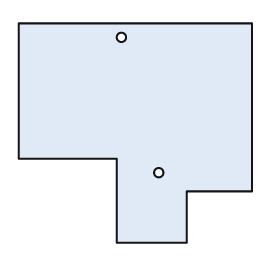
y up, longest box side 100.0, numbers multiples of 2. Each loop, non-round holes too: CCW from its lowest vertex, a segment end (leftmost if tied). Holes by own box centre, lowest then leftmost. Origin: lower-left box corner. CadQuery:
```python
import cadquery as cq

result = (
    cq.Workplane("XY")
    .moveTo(42.0, 0.0)
    .lineTo(72.0, 0.0)
    .lineTo(72.0, 22.0)
    .lineTo(100.0, 22.0)
    .lineTo(100.0, 94.0)
    .lineTo(0.0, 94.0)
    .lineTo(0.0, 36.0)
    .lineTo(42.0, 36.0)
    .close()
    .moveTo(60.0, 30.0)
    .circle(2.0)
    .moveTo(44.0, 88.0)
    .circle(2.0)
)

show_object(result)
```